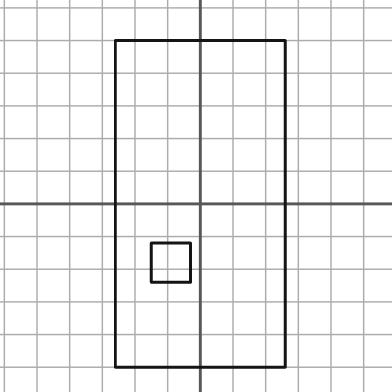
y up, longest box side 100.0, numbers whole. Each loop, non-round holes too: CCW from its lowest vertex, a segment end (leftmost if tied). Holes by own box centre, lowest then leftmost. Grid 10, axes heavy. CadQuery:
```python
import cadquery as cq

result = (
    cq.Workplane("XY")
    .moveTo(-26.0, -50.0)
    .lineTo(26.0, -50.0)
    .lineTo(26.0, 50.0)
    .lineTo(-26.0, 50.0)
    .close()
    .moveTo(-15.0, -24.0)
    .lineTo(-3.0, -24.0)
    .lineTo(-3.0, -12.0)
    .lineTo(-15.0, -12.0)
    .close()
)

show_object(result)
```